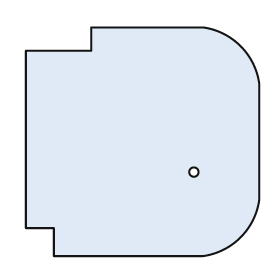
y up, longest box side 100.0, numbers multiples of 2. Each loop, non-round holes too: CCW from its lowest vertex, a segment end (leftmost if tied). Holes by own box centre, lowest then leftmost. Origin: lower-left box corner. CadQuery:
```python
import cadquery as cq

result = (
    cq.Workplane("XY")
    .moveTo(12.0, 0.0)
    .lineTo(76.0, 0.0)
    .threePointArc((92.0, 8.0), (100.0, 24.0))
    .lineTo(100.0, 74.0)
    .threePointArc((92.0, 90.0), (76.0, 98.0))
    .lineTo(28.0, 98.0)
    .lineTo(28.0, 88.0)
    .lineTo(0.0, 88.0)
    .lineTo(0.0, 12.0)
    .lineTo(12.0, 12.0)
    .close()
    .moveTo(72.0, 36.0)
    .circle(2.0)
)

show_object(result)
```